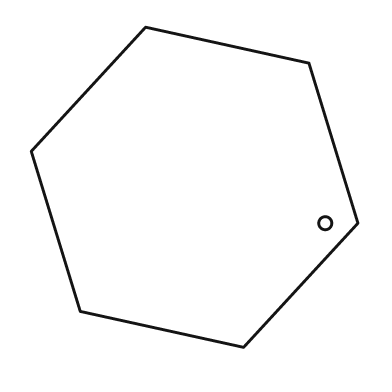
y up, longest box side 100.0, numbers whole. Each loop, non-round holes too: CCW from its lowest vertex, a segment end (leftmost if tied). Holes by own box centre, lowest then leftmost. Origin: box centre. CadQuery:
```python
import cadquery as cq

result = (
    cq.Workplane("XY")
    .moveTo(15.0, -49.0)
    .lineTo(50.0, -11.0)
    .lineTo(35.0, 38.0)
    .lineTo(-15.0, 49.0)
    .lineTo(-50.0, 11.0)
    .lineTo(-35.0, -38.0)
    .close()
    .moveTo(40.0, -11.0)
    .circle(2.0)
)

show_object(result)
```